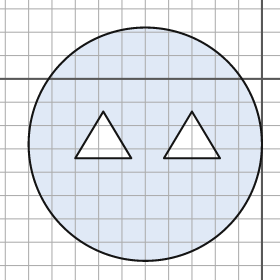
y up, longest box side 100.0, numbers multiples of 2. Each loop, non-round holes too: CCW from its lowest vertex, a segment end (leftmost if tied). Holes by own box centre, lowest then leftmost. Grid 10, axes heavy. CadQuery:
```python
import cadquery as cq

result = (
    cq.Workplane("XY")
    .moveTo(-50.0, -28.0)
    .circle(50.0)
    .moveTo(-80.0, -34.0)
    .lineTo(-56.0, -34.0)
    .lineTo(-68.0, -14.0)
    .close()
    .moveTo(-42.0, -34.0)
    .lineTo(-18.0, -34.0)
    .lineTo(-30.0, -14.0)
    .close()
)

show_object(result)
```